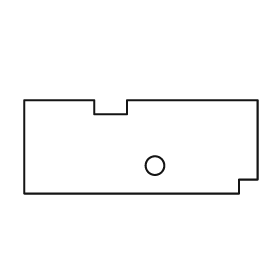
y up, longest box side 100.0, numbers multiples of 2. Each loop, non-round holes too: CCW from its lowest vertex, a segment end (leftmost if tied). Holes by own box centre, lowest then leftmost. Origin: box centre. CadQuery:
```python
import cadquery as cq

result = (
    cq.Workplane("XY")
    .moveTo(-50.0, -20.0)
    .lineTo(42.0, -20.0)
    .lineTo(42.0, -14.0)
    .lineTo(50.0, -14.0)
    .lineTo(50.0, 20.0)
    .lineTo(-6.0, 20.0)
    .lineTo(-6.0, 14.0)
    .lineTo(-20.0, 14.0)
    .lineTo(-20.0, 20.0)
    .lineTo(-50.0, 20.0)
    .close()
    .moveTo(6.0, -8.0)
    .circle(4.0)
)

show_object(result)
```